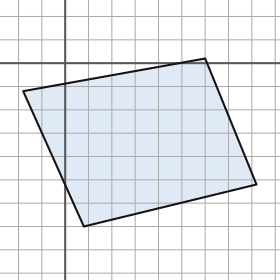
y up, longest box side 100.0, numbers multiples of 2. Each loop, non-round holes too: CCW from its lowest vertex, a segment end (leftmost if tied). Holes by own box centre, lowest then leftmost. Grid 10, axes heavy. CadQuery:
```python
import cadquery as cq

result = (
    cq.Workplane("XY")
    .moveTo(8.0, -70.0)
    .lineTo(82.0, -52.0)
    .lineTo(60.0, 2.0)
    .lineTo(-18.0, -12.0)
    .close()
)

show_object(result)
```